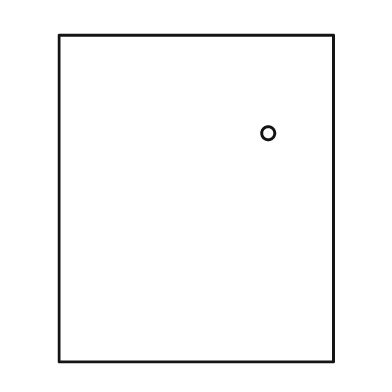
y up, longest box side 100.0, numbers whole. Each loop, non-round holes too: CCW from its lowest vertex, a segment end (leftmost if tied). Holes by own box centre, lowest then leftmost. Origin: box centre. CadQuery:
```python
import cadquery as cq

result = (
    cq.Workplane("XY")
    .moveTo(-42.0, -50.0)
    .lineTo(42.0, -50.0)
    .lineTo(42.0, 50.0)
    .lineTo(-42.0, 50.0)
    .close()
    .moveTo(22.0, 20.0)
    .circle(2.0)
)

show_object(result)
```